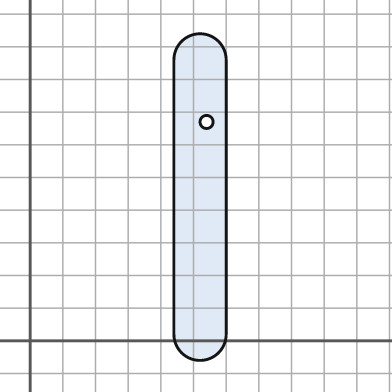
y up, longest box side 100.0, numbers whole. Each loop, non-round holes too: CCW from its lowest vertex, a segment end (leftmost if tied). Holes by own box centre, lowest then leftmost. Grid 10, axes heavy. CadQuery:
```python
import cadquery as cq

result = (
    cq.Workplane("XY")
    .moveTo(44.0, 2.0)
    .threePointArc((52.0, -6.0), (60.0, 2.0))
    .lineTo(60.0, 86.0)
    .threePointArc((52.0, 94.0), (44.0, 86.0))
    .close()
    .moveTo(54.0, 67.0)
    .circle(2.0)
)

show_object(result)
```